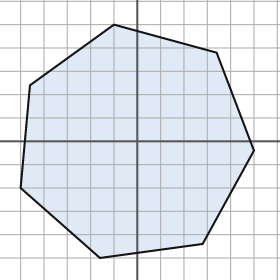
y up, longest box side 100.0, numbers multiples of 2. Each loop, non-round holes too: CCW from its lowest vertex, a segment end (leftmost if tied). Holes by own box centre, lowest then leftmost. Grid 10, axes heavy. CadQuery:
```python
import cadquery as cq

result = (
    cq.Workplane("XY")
    .moveTo(-16.0, -50.0)
    .lineTo(28.0, -44.0)
    .lineTo(50.0, -4.0)
    .lineTo(34.0, 38.0)
    .lineTo(-10.0, 50.0)
    .lineTo(-46.0, 24.0)
    .lineTo(-50.0, -20.0)
    .close()
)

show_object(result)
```